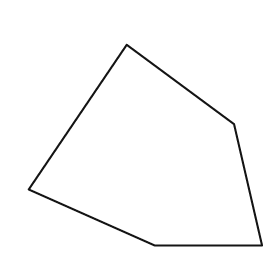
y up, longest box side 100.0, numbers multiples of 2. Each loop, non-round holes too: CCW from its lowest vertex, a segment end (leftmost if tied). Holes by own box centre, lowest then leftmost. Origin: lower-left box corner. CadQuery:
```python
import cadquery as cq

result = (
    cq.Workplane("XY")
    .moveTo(54.0, 0.0)
    .lineTo(100.0, 0.0)
    .lineTo(88.0, 52.0)
    .lineTo(42.0, 86.0)
    .lineTo(0.0, 24.0)
    .close()
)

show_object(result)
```